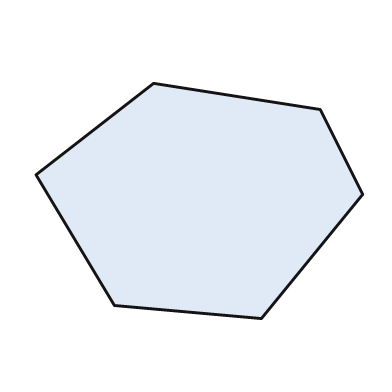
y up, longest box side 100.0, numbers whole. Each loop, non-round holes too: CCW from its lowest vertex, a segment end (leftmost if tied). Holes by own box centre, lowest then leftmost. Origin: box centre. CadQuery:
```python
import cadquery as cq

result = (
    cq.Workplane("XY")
    .moveTo(19.0, -36.0)
    .lineTo(50.0, 2.0)
    .lineTo(37.0, 28.0)
    .lineTo(-14.0, 36.0)
    .lineTo(-50.0, 8.0)
    .lineTo(-26.0, -32.0)
    .close()
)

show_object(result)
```